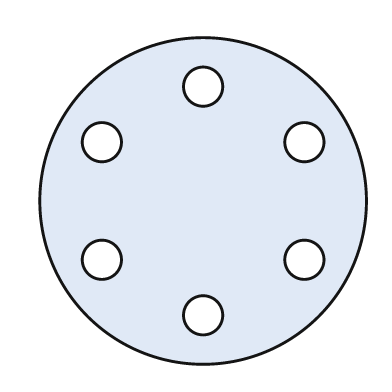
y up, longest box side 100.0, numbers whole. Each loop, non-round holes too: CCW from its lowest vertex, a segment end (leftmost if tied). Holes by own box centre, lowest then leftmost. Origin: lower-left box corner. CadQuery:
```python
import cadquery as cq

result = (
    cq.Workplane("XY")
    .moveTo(50.0, 50.0)
    .circle(50.0)
    .moveTo(50.0, 15.0)
    .circle(6.0)
    .moveTo(19.0, 32.0)
    .circle(6.0)
    .moveTo(81.0, 32.0)
    .circle(6.0)
    .moveTo(19.0, 68.0)
    .circle(6.0)
    .moveTo(81.0, 68.0)
    .circle(6.0)
    .moveTo(50.0, 85.0)
    .circle(6.0)
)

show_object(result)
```